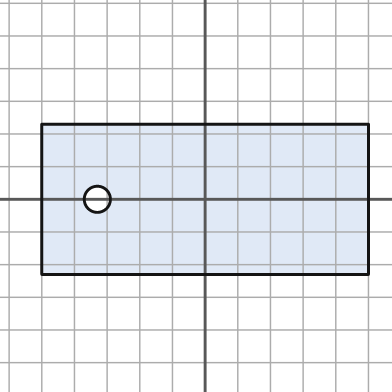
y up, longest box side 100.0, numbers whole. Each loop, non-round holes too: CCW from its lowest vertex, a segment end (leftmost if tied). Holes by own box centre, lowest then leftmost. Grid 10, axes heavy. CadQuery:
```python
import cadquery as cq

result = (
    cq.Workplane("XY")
    .moveTo(-50.0, -23.0)
    .lineTo(50.0, -23.0)
    .lineTo(50.0, 23.0)
    .lineTo(-50.0, 23.0)
    .close()
    .moveTo(-33.0, 0.0)
    .circle(4.0)
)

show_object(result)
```